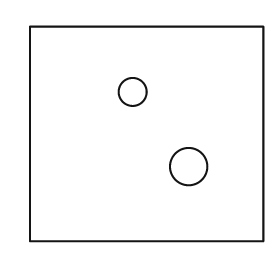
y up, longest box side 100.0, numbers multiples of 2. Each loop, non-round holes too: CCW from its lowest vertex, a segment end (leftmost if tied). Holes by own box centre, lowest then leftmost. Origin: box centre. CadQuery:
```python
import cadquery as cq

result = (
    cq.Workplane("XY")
    .moveTo(-50.0, -46.0)
    .lineTo(50.0, -46.0)
    .lineTo(50.0, 46.0)
    .lineTo(-50.0, 46.0)
    .close()
    .moveTo(18.0, -14.0)
    .circle(8.0)
    .moveTo(-6.0, 18.0)
    .circle(6.0)
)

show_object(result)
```